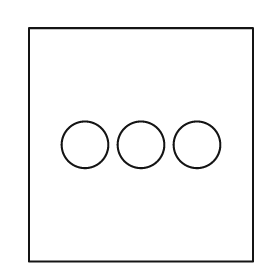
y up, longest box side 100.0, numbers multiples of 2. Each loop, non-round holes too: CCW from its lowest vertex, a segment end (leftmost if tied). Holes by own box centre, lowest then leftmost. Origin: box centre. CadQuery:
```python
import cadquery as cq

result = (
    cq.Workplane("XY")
    .moveTo(-48.0, -50.0)
    .lineTo(48.0, -50.0)
    .lineTo(48.0, 50.0)
    .lineTo(-48.0, 50.0)
    .close()
    .moveTo(-24.0, 0.0)
    .circle(10.0)
    .moveTo(0.0, 0.0)
    .circle(10.0)
    .moveTo(24.0, 0.0)
    .circle(10.0)
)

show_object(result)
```